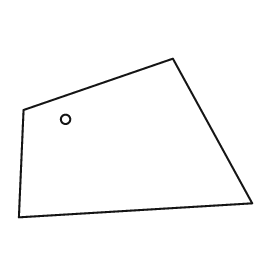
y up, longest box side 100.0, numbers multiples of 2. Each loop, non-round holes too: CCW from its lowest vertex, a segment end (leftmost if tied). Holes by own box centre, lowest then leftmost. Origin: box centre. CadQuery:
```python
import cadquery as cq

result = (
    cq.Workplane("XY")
    .moveTo(-50.0, -34.0)
    .lineTo(50.0, -28.0)
    .lineTo(16.0, 34.0)
    .lineTo(-48.0, 12.0)
    .close()
    .moveTo(-30.0, 8.0)
    .circle(2.0)
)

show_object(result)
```